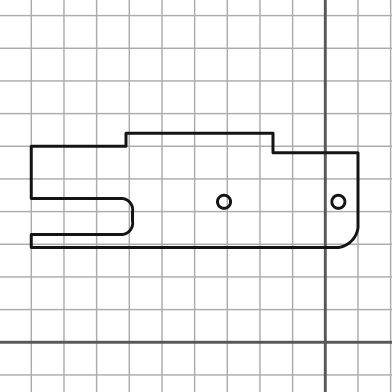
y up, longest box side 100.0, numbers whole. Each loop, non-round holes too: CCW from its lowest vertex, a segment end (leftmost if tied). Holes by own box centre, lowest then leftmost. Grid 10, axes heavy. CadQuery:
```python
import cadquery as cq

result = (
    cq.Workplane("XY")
    .moveTo(-90.0, 29.0)
    .lineTo(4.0, 29.0)
    .threePointArc((8.0, 31.0), (10.0, 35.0))
    .lineTo(10.0, 58.0)
    .lineTo(-16.0, 58.0)
    .lineTo(-16.0, 64.0)
    .lineTo(-61.0, 64.0)
    .lineTo(-61.0, 60.0)
    .lineTo(-90.0, 60.0)
    .lineTo(-90.0, 44.0)
    .lineTo(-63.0, 44.0)
    .threePointArc((-60.0, 43.0), (-59.0, 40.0))
    .lineTo(-59.0, 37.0)
    .threePointArc((-60.0, 34.0), (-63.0, 33.0))
    .lineTo(-90.0, 33.0)
    .close()
    .moveTo(-31.0, 43.0)
    .circle(2.0)
    .moveTo(4.0, 43.0)
    .circle(2.0)
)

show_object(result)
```